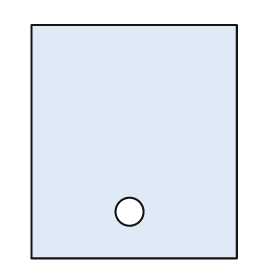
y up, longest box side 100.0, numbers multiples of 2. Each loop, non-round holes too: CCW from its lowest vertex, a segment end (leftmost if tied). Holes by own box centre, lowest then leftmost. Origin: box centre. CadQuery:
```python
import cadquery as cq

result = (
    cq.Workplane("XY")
    .moveTo(-44.0, -50.0)
    .lineTo(44.0, -50.0)
    .lineTo(44.0, 50.0)
    .lineTo(-44.0, 50.0)
    .close()
    .moveTo(-2.0, -30.0)
    .circle(6.0)
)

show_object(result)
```